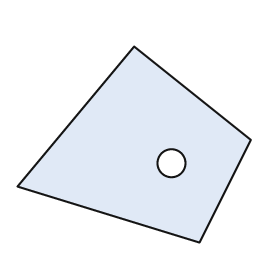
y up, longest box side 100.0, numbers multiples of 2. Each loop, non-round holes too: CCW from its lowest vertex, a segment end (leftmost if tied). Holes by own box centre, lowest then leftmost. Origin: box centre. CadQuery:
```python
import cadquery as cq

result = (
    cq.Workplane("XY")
    .moveTo(28.0, -42.0)
    .lineTo(50.0, 2.0)
    .lineTo(0.0, 42.0)
    .lineTo(-50.0, -18.0)
    .close()
    .moveTo(16.0, -8.0)
    .circle(6.0)
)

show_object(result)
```